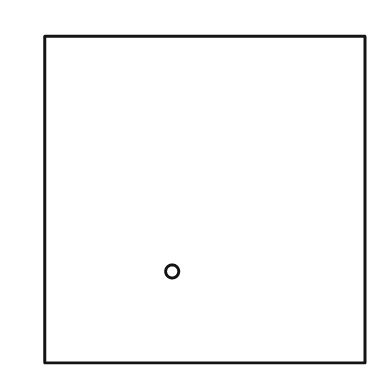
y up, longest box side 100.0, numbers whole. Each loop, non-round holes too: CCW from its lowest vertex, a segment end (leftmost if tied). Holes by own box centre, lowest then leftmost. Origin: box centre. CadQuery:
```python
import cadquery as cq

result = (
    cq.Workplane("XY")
    .moveTo(-49.0, -50.0)
    .lineTo(49.0, -50.0)
    .lineTo(49.0, 50.0)
    .lineTo(-49.0, 50.0)
    .close()
    .moveTo(-10.0, -22.0)
    .circle(2.0)
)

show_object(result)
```